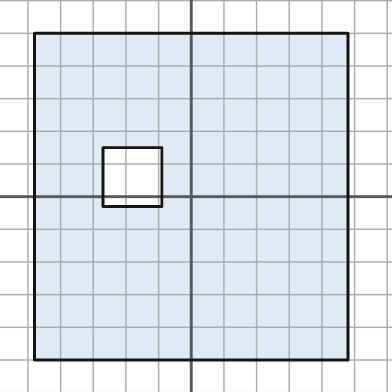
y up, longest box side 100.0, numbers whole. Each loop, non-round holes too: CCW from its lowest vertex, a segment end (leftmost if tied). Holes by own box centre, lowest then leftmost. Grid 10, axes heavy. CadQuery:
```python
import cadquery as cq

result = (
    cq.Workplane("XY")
    .moveTo(-48.0, -50.0)
    .lineTo(48.0, -50.0)
    .lineTo(48.0, 50.0)
    .lineTo(-48.0, 50.0)
    .close()
    .moveTo(-27.0, -3.0)
    .lineTo(-9.0, -3.0)
    .lineTo(-9.0, 15.0)
    .lineTo(-27.0, 15.0)
    .close()
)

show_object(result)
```